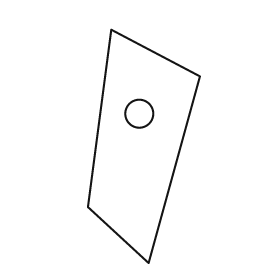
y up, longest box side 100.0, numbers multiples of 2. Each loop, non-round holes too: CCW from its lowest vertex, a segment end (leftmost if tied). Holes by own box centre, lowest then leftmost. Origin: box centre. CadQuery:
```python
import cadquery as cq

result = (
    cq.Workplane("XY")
    .moveTo(2.0, -50.0)
    .lineTo(24.0, 30.0)
    .lineTo(-14.0, 50.0)
    .lineTo(-24.0, -26.0)
    .close()
    .moveTo(-2.0, 14.0)
    .circle(6.0)
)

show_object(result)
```